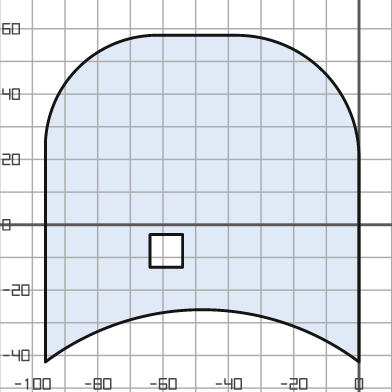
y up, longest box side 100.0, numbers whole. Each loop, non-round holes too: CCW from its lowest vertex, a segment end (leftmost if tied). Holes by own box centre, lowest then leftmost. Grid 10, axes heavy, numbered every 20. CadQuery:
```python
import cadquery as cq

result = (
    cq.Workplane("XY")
    .moveTo(-96.0, -42.0)
    .threePointArc((-48.0, -26.0), (0.0, -42.0))
    .lineTo(0.0, 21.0)
    .threePointArc((-11.0, 47.0), (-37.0, 58.0))
    .lineTo(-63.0, 58.0)
    .threePointArc((-86.0, 48.0), (-96.0, 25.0))
    .close()
    .moveTo(-64.0, -13.0)
    .lineTo(-54.0, -13.0)
    .lineTo(-54.0, -3.0)
    .lineTo(-64.0, -3.0)
    .close()
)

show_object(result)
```